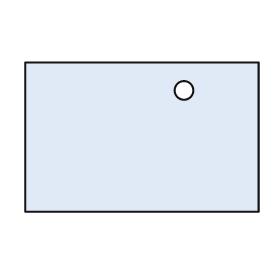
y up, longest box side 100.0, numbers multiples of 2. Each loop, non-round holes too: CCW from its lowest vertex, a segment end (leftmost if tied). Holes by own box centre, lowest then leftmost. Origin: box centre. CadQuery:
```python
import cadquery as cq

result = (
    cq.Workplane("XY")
    .moveTo(-50.0, -32.0)
    .lineTo(50.0, -32.0)
    .lineTo(50.0, 32.0)
    .lineTo(-50.0, 32.0)
    .close()
    .moveTo(18.0, 20.0)
    .circle(4.0)
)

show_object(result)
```